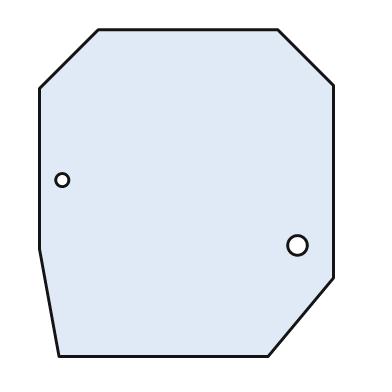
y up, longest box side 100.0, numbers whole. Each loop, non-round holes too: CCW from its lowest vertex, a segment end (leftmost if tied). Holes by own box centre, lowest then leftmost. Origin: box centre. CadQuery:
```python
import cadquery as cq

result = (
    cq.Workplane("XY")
    .moveTo(-39.0, -50.0)
    .lineTo(25.0, -50.0)
    .lineTo(45.0, -26.0)
    .lineTo(45.0, 33.0)
    .lineTo(28.0, 50.0)
    .lineTo(-27.0, 50.0)
    .lineTo(-45.0, 32.0)
    .lineTo(-45.0, -17.0)
    .close()
    .moveTo(34.0, -16.0)
    .circle(3.0)
    .moveTo(-38.0, 4.0)
    .circle(2.0)
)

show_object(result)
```